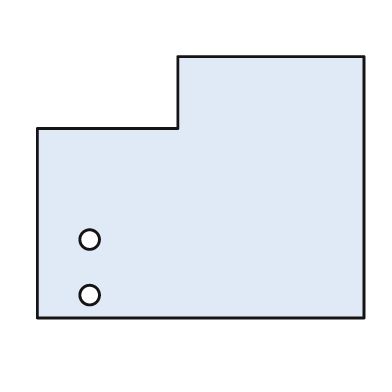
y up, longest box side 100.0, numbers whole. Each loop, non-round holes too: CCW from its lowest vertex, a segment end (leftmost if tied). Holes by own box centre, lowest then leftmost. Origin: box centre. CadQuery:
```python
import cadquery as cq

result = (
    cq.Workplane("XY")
    .moveTo(-50.0, -40.0)
    .lineTo(50.0, -40.0)
    .lineTo(50.0, 40.0)
    .lineTo(-7.0, 40.0)
    .lineTo(-7.0, 18.0)
    .lineTo(-50.0, 18.0)
    .close()
    .moveTo(-34.0, -33.0)
    .circle(3.0)
    .moveTo(-34.0, -16.0)
    .circle(3.0)
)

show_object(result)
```